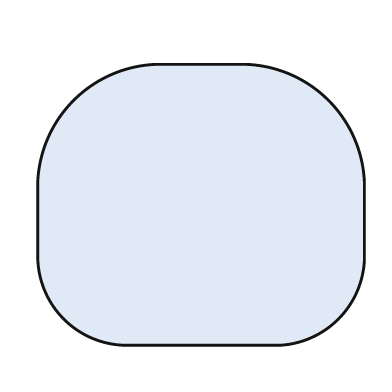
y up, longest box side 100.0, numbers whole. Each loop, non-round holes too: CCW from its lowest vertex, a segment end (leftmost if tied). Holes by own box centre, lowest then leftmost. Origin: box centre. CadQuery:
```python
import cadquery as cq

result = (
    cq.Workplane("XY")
    .moveTo(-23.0, -43.0)
    .lineTo(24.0, -43.0)
    .threePointArc((42.0, -35.0), (50.0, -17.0))
    .lineTo(50.0, 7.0)
    .threePointArc((39.0, 32.0), (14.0, 43.0))
    .lineTo(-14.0, 43.0)
    .threePointArc((-39.0, 32.0), (-50.0, 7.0))
    .lineTo(-50.0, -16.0)
    .threePointArc((-42.0, -35.0), (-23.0, -43.0))
    .close()
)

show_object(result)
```